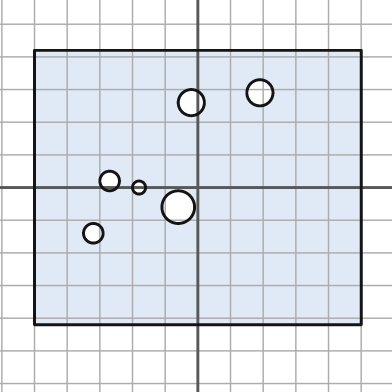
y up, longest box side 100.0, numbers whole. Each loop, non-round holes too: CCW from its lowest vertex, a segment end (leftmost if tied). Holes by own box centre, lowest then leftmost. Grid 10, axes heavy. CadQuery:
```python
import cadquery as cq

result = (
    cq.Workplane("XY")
    .moveTo(-50.0, -42.0)
    .lineTo(50.0, -42.0)
    .lineTo(50.0, 42.0)
    .lineTo(-50.0, 42.0)
    .close()
    .moveTo(-32.0, -14.0)
    .circle(3.0)
    .moveTo(-6.0, -6.0)
    .circle(5.0)
    .moveTo(-18.0, 0.0)
    .circle(2.0)
    .moveTo(-27.0, 2.0)
    .circle(3.0)
    .moveTo(-2.0, 26.0)
    .circle(4.0)
    .moveTo(19.0, 29.0)
    .circle(4.0)
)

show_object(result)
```